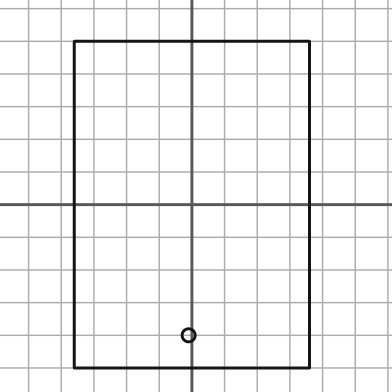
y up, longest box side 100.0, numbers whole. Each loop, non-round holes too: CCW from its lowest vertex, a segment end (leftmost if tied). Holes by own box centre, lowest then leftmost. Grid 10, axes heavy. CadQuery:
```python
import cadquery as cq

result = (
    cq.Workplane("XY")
    .moveTo(-36.0, -50.0)
    .lineTo(36.0, -50.0)
    .lineTo(36.0, 50.0)
    .lineTo(-36.0, 50.0)
    .close()
    .moveTo(-1.0, -40.0)
    .circle(2.0)
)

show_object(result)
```